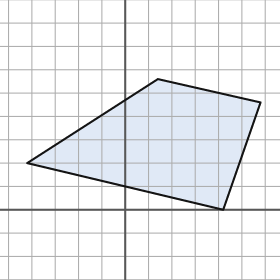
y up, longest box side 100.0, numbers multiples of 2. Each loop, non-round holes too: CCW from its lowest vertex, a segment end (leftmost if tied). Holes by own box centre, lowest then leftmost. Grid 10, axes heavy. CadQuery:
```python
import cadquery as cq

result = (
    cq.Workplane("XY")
    .moveTo(42.0, 0.0)
    .lineTo(58.0, 46.0)
    .lineTo(14.0, 56.0)
    .lineTo(-42.0, 20.0)
    .close()
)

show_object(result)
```